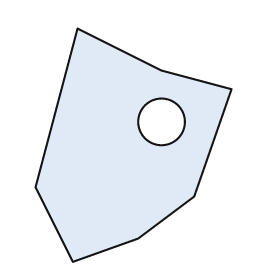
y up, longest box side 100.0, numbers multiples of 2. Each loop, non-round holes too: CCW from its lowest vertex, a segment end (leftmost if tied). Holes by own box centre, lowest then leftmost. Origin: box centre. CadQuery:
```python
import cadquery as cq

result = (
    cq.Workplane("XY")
    .moveTo(-26.0, -50.0)
    .lineTo(2.0, -40.0)
    .lineTo(26.0, -22.0)
    .lineTo(42.0, 24.0)
    .lineTo(12.0, 32.0)
    .lineTo(-24.0, 50.0)
    .lineTo(-42.0, -18.0)
    .close()
    .moveTo(12.0, 10.0)
    .circle(10.0)
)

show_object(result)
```